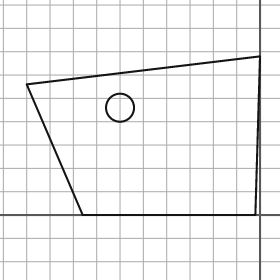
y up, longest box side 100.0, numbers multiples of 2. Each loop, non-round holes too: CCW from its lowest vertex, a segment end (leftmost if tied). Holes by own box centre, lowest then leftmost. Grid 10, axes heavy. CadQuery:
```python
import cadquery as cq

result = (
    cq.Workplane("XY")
    .moveTo(-76.0, 0.0)
    .lineTo(-2.0, 0.0)
    .lineTo(0.0, 68.0)
    .lineTo(-100.0, 56.0)
    .close()
    .moveTo(-60.0, 46.0)
    .circle(6.0)
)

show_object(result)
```